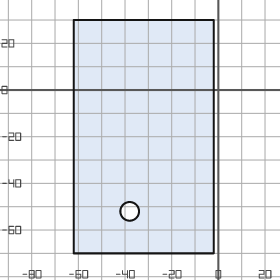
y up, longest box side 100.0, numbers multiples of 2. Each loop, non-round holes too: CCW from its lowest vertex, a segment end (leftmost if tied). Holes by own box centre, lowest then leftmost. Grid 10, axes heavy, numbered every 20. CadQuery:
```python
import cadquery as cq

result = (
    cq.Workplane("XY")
    .moveTo(-62.0, -70.0)
    .lineTo(-2.0, -70.0)
    .lineTo(-2.0, 30.0)
    .lineTo(-62.0, 30.0)
    .close()
    .moveTo(-38.0, -52.0)
    .circle(4.0)
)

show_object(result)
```